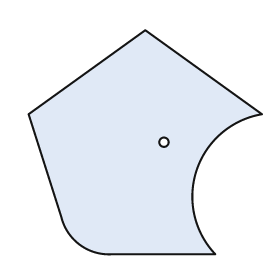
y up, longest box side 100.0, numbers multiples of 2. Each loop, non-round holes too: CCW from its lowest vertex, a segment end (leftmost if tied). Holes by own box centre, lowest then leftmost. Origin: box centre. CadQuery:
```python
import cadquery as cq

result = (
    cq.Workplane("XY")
    .moveTo(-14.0, -48.0)
    .lineTo(30.0, -48.0)
    .threePointArc((22.0, -12.0), (50.0, 12.0))
    .lineTo(0.0, 48.0)
    .lineTo(-50.0, 12.0)
    .lineTo(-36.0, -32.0)
    .threePointArc((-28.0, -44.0), (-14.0, -48.0))
    .close()
    .moveTo(8.0, 0.0)
    .circle(2.0)
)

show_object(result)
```